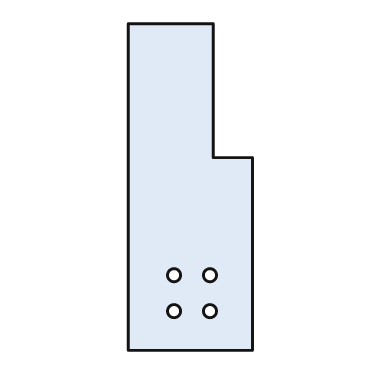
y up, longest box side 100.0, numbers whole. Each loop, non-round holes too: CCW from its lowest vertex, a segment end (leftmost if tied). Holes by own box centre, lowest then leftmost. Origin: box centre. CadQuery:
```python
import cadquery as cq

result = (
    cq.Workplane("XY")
    .moveTo(-19.0, -50.0)
    .lineTo(19.0, -50.0)
    .lineTo(19.0, 9.0)
    .lineTo(7.0, 9.0)
    .lineTo(7.0, 50.0)
    .lineTo(-19.0, 50.0)
    .close()
    .moveTo(-5.0, -38.0)
    .circle(2.0)
    .moveTo(6.0, -38.0)
    .circle(2.0)
    .moveTo(-5.0, -27.0)
    .circle(2.0)
    .moveTo(6.0, -27.0)
    .circle(2.0)
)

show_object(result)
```